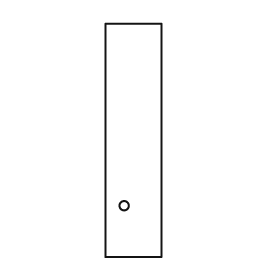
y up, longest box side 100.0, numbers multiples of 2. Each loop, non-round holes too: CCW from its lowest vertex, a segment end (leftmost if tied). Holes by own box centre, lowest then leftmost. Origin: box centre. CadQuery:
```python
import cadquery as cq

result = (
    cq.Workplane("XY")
    .moveTo(-12.0, -50.0)
    .lineTo(12.0, -50.0)
    .lineTo(12.0, 50.0)
    .lineTo(-12.0, 50.0)
    .close()
    .moveTo(-4.0, -28.0)
    .circle(2.0)
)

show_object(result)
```